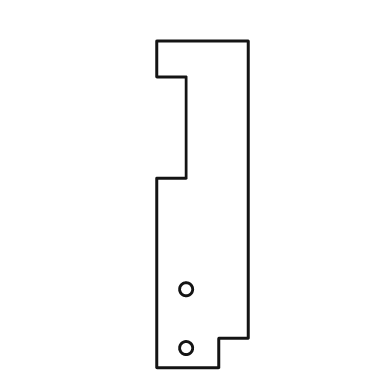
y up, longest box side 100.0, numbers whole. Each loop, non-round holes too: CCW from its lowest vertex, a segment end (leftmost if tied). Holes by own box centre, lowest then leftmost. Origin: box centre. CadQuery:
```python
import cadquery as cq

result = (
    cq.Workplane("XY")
    .moveTo(-14.0, -50.0)
    .lineTo(5.0, -50.0)
    .lineTo(5.0, -41.0)
    .lineTo(14.0, -41.0)
    .lineTo(14.0, 50.0)
    .lineTo(-14.0, 50.0)
    .lineTo(-14.0, 39.0)
    .lineTo(-5.0, 39.0)
    .lineTo(-5.0, 8.0)
    .lineTo(-14.0, 8.0)
    .close()
    .moveTo(-5.0, -44.0)
    .circle(2.0)
    .moveTo(-5.0, -26.0)
    .circle(2.0)
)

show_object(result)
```